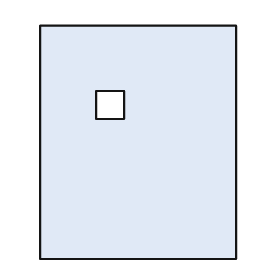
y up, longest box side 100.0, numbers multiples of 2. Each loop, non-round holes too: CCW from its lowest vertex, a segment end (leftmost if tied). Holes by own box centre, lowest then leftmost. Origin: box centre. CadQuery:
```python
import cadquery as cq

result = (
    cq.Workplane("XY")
    .moveTo(-42.0, -50.0)
    .lineTo(42.0, -50.0)
    .lineTo(42.0, 50.0)
    .lineTo(-42.0, 50.0)
    .close()
    .moveTo(-18.0, 10.0)
    .lineTo(-6.0, 10.0)
    .lineTo(-6.0, 22.0)
    .lineTo(-18.0, 22.0)
    .close()
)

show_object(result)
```